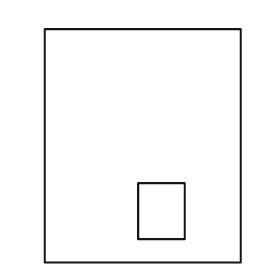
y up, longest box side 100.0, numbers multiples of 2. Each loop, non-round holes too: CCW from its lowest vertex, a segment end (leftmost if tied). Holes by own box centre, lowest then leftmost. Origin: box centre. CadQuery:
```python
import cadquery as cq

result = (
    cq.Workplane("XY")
    .moveTo(-42.0, -50.0)
    .lineTo(42.0, -50.0)
    .lineTo(42.0, 50.0)
    .lineTo(-42.0, 50.0)
    .close()
    .moveTo(-2.0, -40.0)
    .lineTo(18.0, -40.0)
    .lineTo(18.0, -16.0)
    .lineTo(-2.0, -16.0)
    .close()
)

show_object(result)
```